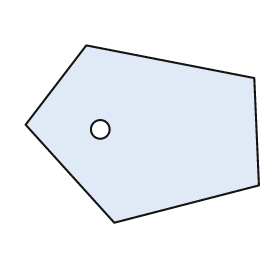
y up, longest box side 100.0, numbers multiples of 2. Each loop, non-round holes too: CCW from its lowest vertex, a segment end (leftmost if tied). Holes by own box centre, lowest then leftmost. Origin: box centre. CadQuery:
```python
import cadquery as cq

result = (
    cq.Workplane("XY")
    .moveTo(-12.0, -38.0)
    .lineTo(50.0, -22.0)
    .lineTo(48.0, 24.0)
    .lineTo(-24.0, 38.0)
    .lineTo(-50.0, 4.0)
    .close()
    .moveTo(-18.0, 2.0)
    .circle(4.0)
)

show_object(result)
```